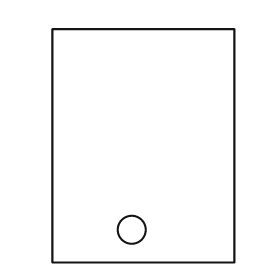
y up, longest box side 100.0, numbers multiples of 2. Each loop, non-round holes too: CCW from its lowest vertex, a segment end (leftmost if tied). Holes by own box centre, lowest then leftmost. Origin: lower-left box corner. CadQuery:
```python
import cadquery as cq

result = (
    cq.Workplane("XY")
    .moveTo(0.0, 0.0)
    .lineTo(78.0, 0.0)
    .lineTo(78.0, 100.0)
    .lineTo(0.0, 100.0)
    .close()
    .moveTo(34.0, 14.0)
    .circle(6.0)
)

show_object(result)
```